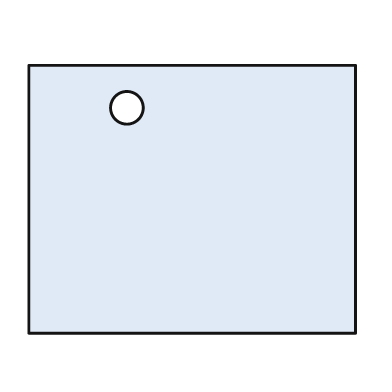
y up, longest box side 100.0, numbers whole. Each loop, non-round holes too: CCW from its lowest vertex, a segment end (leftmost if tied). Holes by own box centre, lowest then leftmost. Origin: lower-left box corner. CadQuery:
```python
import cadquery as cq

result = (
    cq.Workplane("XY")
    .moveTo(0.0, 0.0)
    .lineTo(100.0, 0.0)
    .lineTo(100.0, 82.0)
    .lineTo(0.0, 82.0)
    .close()
    .moveTo(30.0, 69.0)
    .circle(5.0)
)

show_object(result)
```